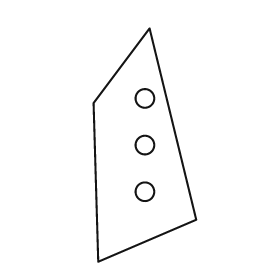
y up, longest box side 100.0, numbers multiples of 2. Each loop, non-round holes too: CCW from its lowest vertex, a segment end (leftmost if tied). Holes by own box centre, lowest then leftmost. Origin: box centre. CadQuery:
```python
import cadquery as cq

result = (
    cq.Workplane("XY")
    .moveTo(-20.0, -50.0)
    .lineTo(22.0, -32.0)
    .lineTo(2.0, 50.0)
    .lineTo(-22.0, 18.0)
    .close()
    .moveTo(0.0, -20.0)
    .circle(4.0)
    .moveTo(0.0, 0.0)
    .circle(4.0)
    .moveTo(0.0, 20.0)
    .circle(4.0)
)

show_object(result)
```